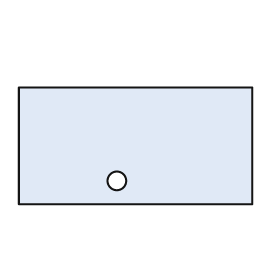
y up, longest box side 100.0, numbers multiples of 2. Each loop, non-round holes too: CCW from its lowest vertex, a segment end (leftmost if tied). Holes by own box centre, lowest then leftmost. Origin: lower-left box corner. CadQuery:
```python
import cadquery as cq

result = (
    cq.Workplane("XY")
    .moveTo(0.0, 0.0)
    .lineTo(100.0, 0.0)
    .lineTo(100.0, 50.0)
    .lineTo(0.0, 50.0)
    .close()
    .moveTo(42.0, 10.0)
    .circle(4.0)
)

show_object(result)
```